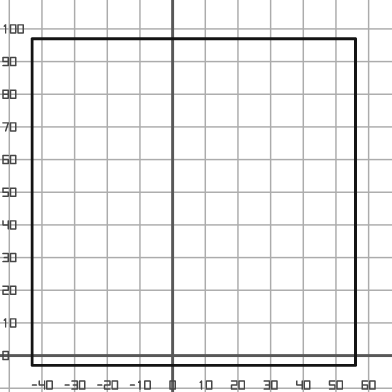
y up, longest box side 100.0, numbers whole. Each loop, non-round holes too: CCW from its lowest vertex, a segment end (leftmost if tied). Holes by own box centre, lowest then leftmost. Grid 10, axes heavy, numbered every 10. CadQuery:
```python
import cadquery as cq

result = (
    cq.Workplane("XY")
    .moveTo(-43.0, -3.0)
    .lineTo(56.0, -3.0)
    .lineTo(56.0, 97.0)
    .lineTo(-43.0, 97.0)
    .close()
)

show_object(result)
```